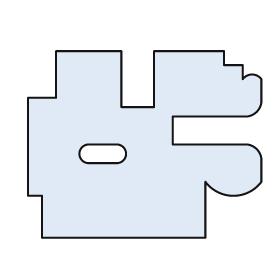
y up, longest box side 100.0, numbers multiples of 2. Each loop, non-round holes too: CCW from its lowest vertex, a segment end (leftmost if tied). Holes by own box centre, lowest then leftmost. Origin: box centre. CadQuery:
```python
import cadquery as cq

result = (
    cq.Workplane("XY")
    .moveTo(-44.0, -40.0)
    .lineTo(26.0, -40.0)
    .lineTo(26.0, -16.0)
    .threePointArc((38.0, -22.0), (50.0, -16.0))
    .lineTo(50.0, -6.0)
    .threePointArc((48.0, -2.0), (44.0, 0.0))
    .lineTo(12.0, 0.0)
    .lineTo(12.0, 12.0)
    .lineTo(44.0, 12.0)
    .threePointArc((48.0, 14.0), (50.0, 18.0))
    .lineTo(50.0, 28.0)
    .threePointArc((46.0, 30.0), (42.0, 28.0))
    .lineTo(42.0, 34.0)
    .lineTo(34.0, 34.0)
    .lineTo(34.0, 40.0)
    .lineTo(4.0, 40.0)
    .lineTo(4.0, 16.0)
    .lineTo(-10.0, 16.0)
    .lineTo(-10.0, 40.0)
    .lineTo(-38.0, 40.0)
    .lineTo(-38.0, 20.0)
    .lineTo(-50.0, 20.0)
    .lineTo(-50.0, -22.0)
    .lineTo(-44.0, -22.0)
    .close()
    .moveTo(-24.0, -8.0)
    .lineTo(-12.0, -8.0)
    .threePointArc((-8.0, -4.0), (-12.0, 0.0))
    .lineTo(-24.0, 0.0)
    .threePointArc((-28.0, -4.0), (-24.0, -8.0))
    .close()
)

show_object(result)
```